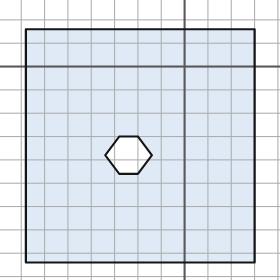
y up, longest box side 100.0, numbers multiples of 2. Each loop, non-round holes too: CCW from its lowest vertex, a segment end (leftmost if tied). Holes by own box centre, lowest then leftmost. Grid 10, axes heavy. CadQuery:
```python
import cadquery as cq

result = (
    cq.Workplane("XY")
    .moveTo(-68.0, -84.0)
    .lineTo(30.0, -84.0)
    .lineTo(30.0, 16.0)
    .lineTo(-68.0, 16.0)
    .close()
    .moveTo(-28.0, -46.0)
    .lineTo(-20.0, -46.0)
    .lineTo(-14.0, -38.0)
    .lineTo(-20.0, -30.0)
    .lineTo(-28.0, -30.0)
    .lineTo(-34.0, -38.0)
    .close()
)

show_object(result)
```